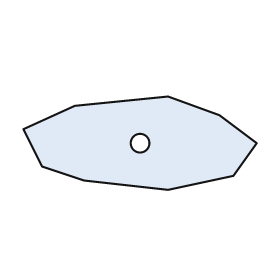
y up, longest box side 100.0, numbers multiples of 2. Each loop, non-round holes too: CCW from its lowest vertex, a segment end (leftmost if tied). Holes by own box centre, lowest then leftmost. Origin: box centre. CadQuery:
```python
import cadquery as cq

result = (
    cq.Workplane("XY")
    .moveTo(12.0, -20.0)
    .lineTo(40.0, -14.0)
    .lineTo(50.0, 0.0)
    .lineTo(34.0, 12.0)
    .lineTo(12.0, 20.0)
    .lineTo(-28.0, 16.0)
    .lineTo(-50.0, 6.0)
    .lineTo(-42.0, -10.0)
    .lineTo(-24.0, -16.0)
    .close()
    .moveTo(0.0, 0.0)
    .circle(4.0)
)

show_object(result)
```